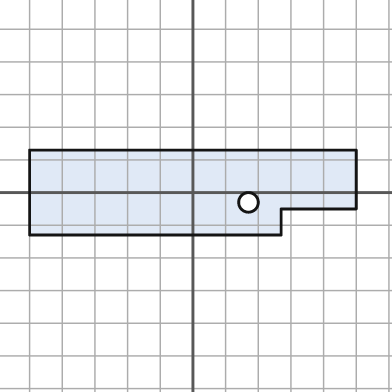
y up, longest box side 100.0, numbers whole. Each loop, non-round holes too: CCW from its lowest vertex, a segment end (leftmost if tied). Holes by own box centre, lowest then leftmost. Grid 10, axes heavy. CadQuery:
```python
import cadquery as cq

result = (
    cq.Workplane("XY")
    .moveTo(-50.0, -13.0)
    .lineTo(27.0, -13.0)
    .lineTo(27.0, -5.0)
    .lineTo(50.0, -5.0)
    .lineTo(50.0, 13.0)
    .lineTo(-50.0, 13.0)
    .close()
    .moveTo(17.0, -3.0)
    .circle(3.0)
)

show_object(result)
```